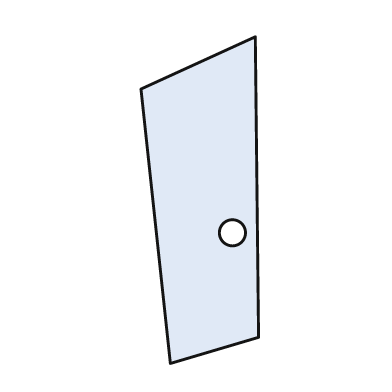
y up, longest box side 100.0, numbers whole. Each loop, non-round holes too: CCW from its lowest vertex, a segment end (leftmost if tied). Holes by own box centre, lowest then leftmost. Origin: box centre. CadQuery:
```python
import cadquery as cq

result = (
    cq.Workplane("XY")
    .moveTo(-9.0, -50.0)
    .lineTo(18.0, -42.0)
    .lineTo(17.0, 50.0)
    .lineTo(-18.0, 34.0)
    .close()
    .moveTo(10.0, -10.0)
    .circle(4.0)
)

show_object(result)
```